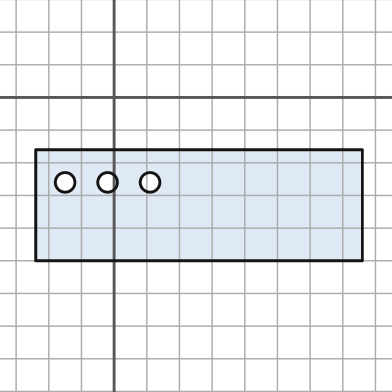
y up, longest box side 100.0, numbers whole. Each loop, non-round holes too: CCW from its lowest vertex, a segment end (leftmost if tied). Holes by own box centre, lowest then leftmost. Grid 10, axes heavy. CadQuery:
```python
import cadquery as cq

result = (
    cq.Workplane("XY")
    .moveTo(-24.0, -50.0)
    .lineTo(76.0, -50.0)
    .lineTo(76.0, -16.0)
    .lineTo(-24.0, -16.0)
    .close()
    .moveTo(-15.0, -26.0)
    .circle(3.0)
    .moveTo(-2.0, -26.0)
    .circle(3.0)
    .moveTo(11.0, -26.0)
    .circle(3.0)
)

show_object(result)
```